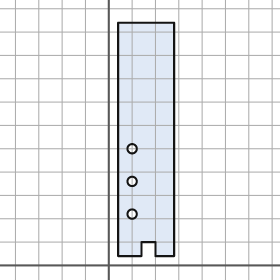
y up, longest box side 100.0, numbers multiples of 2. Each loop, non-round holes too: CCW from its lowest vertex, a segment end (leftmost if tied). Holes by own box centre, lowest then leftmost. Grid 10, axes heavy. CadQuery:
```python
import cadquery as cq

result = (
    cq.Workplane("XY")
    .moveTo(4.0, 4.0)
    .lineTo(14.0, 4.0)
    .lineTo(14.0, 10.0)
    .lineTo(20.0, 10.0)
    .lineTo(20.0, 4.0)
    .lineTo(28.0, 4.0)
    .lineTo(28.0, 104.0)
    .lineTo(4.0, 104.0)
    .close()
    .moveTo(10.0, 22.0)
    .circle(2.0)
    .moveTo(10.0, 36.0)
    .circle(2.0)
    .moveTo(10.0, 50.0)
    .circle(2.0)
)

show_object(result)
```